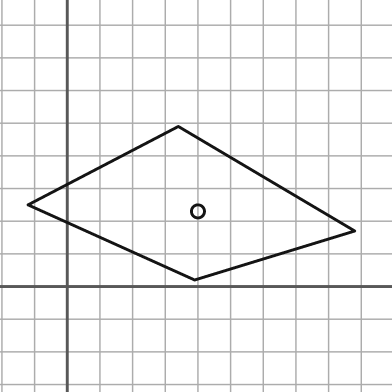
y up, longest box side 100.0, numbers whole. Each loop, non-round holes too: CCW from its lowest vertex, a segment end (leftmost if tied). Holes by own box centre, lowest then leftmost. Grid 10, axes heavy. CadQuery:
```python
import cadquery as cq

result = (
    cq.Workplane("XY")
    .moveTo(39.0, 2.0)
    .lineTo(88.0, 17.0)
    .lineTo(34.0, 49.0)
    .lineTo(-12.0, 25.0)
    .close()
    .moveTo(40.0, 23.0)
    .circle(2.0)
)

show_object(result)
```